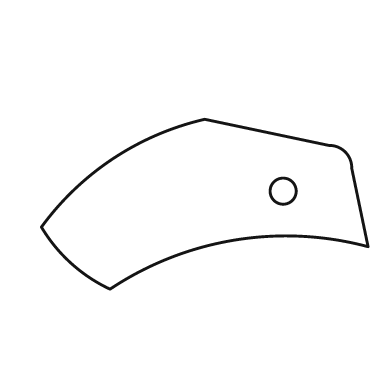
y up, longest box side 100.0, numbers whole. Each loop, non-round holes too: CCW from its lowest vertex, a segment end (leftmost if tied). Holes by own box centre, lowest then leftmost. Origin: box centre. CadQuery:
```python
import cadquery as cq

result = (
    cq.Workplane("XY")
    .moveTo(-29.0, -26.0)
    .threePointArc((9.0, -11.0), (50.0, -13.0))
    .lineTo(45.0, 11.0)
    .threePointArc((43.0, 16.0), (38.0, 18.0))
    .lineTo(0.0, 26.0)
    .threePointArc((-28.0, 14.0), (-50.0, -7.0))
    .threePointArc((-41.0, -18.0), (-29.0, -26.0))
    .close()
    .moveTo(24.0, 4.0)
    .circle(4.0)
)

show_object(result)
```